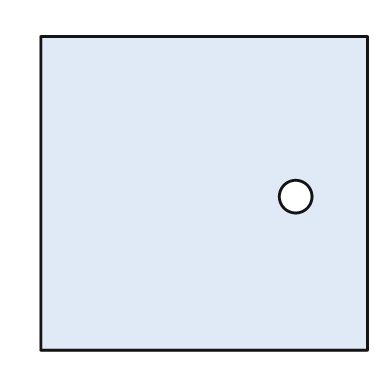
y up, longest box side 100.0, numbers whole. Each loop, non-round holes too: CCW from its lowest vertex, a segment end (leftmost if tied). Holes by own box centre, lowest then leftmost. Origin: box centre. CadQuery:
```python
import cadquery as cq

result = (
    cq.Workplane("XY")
    .moveTo(-50.0, -48.0)
    .lineTo(50.0, -48.0)
    .lineTo(50.0, 48.0)
    .lineTo(-50.0, 48.0)
    .close()
    .moveTo(28.0, -1.0)
    .circle(5.0)
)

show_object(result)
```